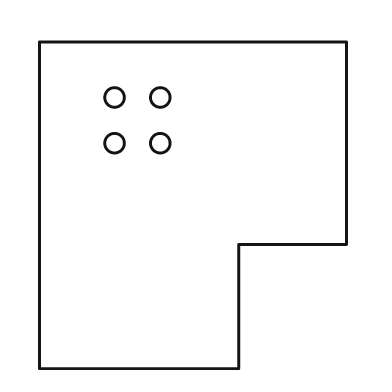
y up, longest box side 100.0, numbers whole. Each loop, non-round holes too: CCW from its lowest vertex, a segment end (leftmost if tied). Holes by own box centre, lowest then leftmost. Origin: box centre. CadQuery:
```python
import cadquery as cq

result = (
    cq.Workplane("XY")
    .moveTo(-47.0, -50.0)
    .lineTo(14.0, -50.0)
    .lineTo(14.0, -12.0)
    .lineTo(47.0, -12.0)
    .lineTo(47.0, 50.0)
    .lineTo(-47.0, 50.0)
    .close()
    .moveTo(-24.0, 19.0)
    .circle(3.0)
    .moveTo(-10.0, 19.0)
    .circle(3.0)
    .moveTo(-24.0, 33.0)
    .circle(3.0)
    .moveTo(-10.0, 33.0)
    .circle(3.0)
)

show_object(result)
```